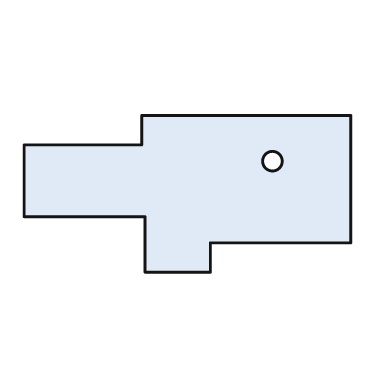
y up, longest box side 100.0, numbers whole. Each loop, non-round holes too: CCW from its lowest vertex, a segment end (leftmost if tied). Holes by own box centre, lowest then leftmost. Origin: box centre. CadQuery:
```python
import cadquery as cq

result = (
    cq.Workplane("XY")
    .moveTo(-13.0, -24.0)
    .lineTo(7.0, -24.0)
    .lineTo(7.0, -15.0)
    .lineTo(50.0, -15.0)
    .lineTo(50.0, 24.0)
    .lineTo(-14.0, 24.0)
    .lineTo(-14.0, 15.0)
    .lineTo(-50.0, 15.0)
    .lineTo(-50.0, -7.0)
    .lineTo(-13.0, -7.0)
    .close()
    .moveTo(26.0, 10.0)
    .circle(3.0)
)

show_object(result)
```